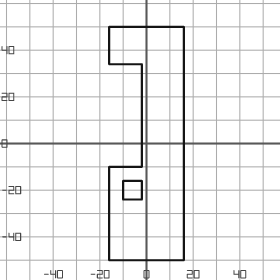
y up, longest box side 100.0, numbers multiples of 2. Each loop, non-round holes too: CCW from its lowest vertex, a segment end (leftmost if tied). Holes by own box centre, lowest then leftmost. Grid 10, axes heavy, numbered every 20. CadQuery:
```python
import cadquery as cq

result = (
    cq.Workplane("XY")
    .moveTo(-16.0, -50.0)
    .lineTo(16.0, -50.0)
    .lineTo(16.0, 50.0)
    .lineTo(-16.0, 50.0)
    .lineTo(-16.0, 34.0)
    .lineTo(-2.0, 34.0)
    .lineTo(-2.0, -10.0)
    .lineTo(-16.0, -10.0)
    .close()
    .moveTo(-10.0, -24.0)
    .lineTo(-2.0, -24.0)
    .lineTo(-2.0, -16.0)
    .lineTo(-10.0, -16.0)
    .close()
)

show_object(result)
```